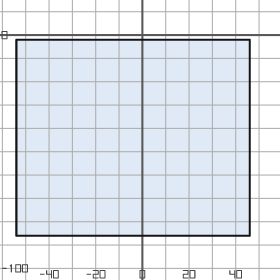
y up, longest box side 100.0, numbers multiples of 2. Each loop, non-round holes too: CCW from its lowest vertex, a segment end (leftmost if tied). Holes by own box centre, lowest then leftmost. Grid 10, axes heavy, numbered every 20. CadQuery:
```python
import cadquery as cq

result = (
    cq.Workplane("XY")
    .moveTo(-54.0, -86.0)
    .lineTo(46.0, -86.0)
    .lineTo(46.0, -2.0)
    .lineTo(-54.0, -2.0)
    .close()
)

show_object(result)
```